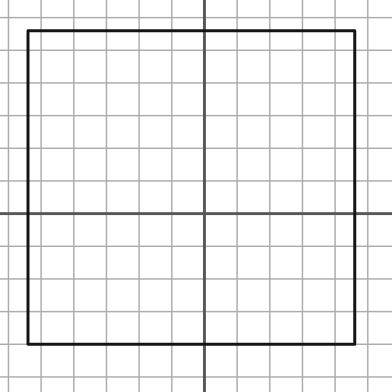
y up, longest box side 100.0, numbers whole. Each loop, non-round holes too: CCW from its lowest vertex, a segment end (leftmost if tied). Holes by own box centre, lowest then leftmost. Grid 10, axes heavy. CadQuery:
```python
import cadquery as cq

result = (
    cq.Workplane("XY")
    .moveTo(-54.0, -40.0)
    .lineTo(46.0, -40.0)
    .lineTo(46.0, 56.0)
    .lineTo(-54.0, 56.0)
    .close()
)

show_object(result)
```